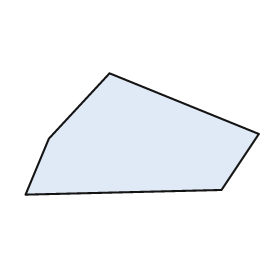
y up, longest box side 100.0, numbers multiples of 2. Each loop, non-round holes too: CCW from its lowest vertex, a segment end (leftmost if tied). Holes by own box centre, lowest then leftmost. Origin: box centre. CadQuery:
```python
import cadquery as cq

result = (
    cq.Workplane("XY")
    .moveTo(-50.0, -26.0)
    .lineTo(34.0, -24.0)
    .lineTo(50.0, 0.0)
    .lineTo(-14.0, 26.0)
    .lineTo(-40.0, -2.0)
    .close()
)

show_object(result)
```